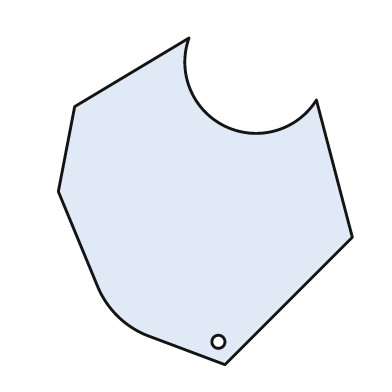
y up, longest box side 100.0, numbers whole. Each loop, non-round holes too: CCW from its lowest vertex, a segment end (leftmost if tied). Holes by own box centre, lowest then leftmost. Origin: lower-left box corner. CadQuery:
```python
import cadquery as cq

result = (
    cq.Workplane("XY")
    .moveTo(51.0, 0.0)
    .lineTo(90.0, 39.0)
    .lineTo(79.0, 81.0)
    .threePointArc((51.0, 73.0), (40.0, 100.0))
    .lineTo(5.0, 79.0)
    .lineTo(0.0, 53.0)
    .lineTo(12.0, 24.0)
    .threePointArc((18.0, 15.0), (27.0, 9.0))
    .close()
    .moveTo(49.0, 7.0)
    .circle(2.0)
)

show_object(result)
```